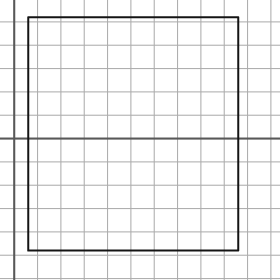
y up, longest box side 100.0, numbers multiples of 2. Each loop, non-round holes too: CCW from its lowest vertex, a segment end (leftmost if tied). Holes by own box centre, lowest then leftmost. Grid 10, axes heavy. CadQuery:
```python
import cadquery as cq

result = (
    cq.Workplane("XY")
    .moveTo(6.0, -48.0)
    .lineTo(96.0, -48.0)
    .lineTo(96.0, 52.0)
    .lineTo(6.0, 52.0)
    .close()
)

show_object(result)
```